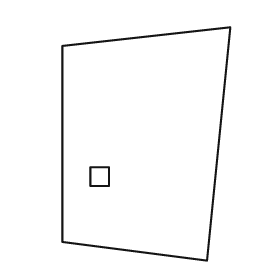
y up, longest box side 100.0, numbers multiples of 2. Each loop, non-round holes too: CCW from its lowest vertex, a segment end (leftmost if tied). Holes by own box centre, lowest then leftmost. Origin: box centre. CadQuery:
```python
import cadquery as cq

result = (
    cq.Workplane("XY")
    .moveTo(26.0, -50.0)
    .lineTo(36.0, 50.0)
    .lineTo(-36.0, 42.0)
    .lineTo(-36.0, -42.0)
    .close()
    .moveTo(-24.0, -18.0)
    .lineTo(-16.0, -18.0)
    .lineTo(-16.0, -10.0)
    .lineTo(-24.0, -10.0)
    .close()
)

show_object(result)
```